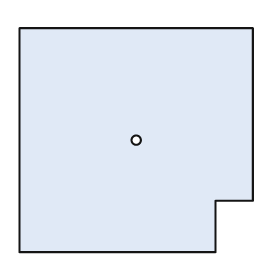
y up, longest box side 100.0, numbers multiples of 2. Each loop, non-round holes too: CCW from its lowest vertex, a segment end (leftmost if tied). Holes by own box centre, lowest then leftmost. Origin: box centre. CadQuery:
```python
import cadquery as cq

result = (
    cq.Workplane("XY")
    .moveTo(-50.0, -48.0)
    .lineTo(34.0, -48.0)
    .lineTo(34.0, -26.0)
    .lineTo(50.0, -26.0)
    .lineTo(50.0, 48.0)
    .lineTo(-50.0, 48.0)
    .close()
    .moveTo(0.0, 0.0)
    .circle(2.0)
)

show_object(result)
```